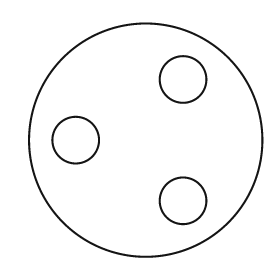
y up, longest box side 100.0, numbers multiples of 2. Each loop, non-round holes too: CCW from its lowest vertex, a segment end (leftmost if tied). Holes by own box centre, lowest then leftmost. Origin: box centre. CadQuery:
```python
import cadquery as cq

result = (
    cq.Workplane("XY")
    .moveTo(0.0, 0.0)
    .circle(50.0)
    .moveTo(16.0, -26.0)
    .circle(10.0)
    .moveTo(-30.0, 0.0)
    .circle(10.0)
    .moveTo(16.0, 26.0)
    .circle(10.0)
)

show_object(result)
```